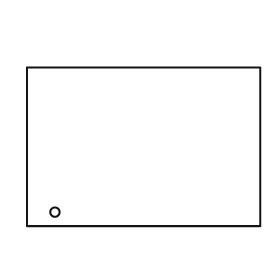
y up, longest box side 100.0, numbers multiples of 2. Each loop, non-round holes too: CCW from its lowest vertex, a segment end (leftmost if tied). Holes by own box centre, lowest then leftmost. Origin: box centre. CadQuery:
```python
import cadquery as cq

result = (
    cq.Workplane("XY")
    .moveTo(-50.0, -34.0)
    .lineTo(50.0, -34.0)
    .lineTo(50.0, 34.0)
    .lineTo(-50.0, 34.0)
    .close()
    .moveTo(-38.0, -28.0)
    .circle(2.0)
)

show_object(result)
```